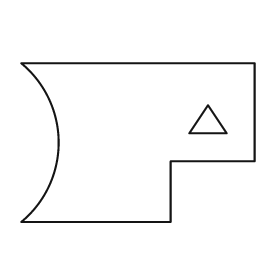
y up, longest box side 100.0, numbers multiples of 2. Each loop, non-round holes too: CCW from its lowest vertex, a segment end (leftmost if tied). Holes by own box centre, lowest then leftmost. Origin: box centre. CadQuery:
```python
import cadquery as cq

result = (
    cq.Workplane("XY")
    .moveTo(-50.0, -34.0)
    .lineTo(14.0, -34.0)
    .lineTo(14.0, -8.0)
    .lineTo(50.0, -8.0)
    .lineTo(50.0, 34.0)
    .lineTo(-50.0, 34.0)
    .threePointArc((-34.0, 0.0), (-50.0, -34.0))
    .close()
    .moveTo(22.0, 4.0)
    .lineTo(38.0, 4.0)
    .lineTo(30.0, 16.0)
    .close()
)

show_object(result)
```